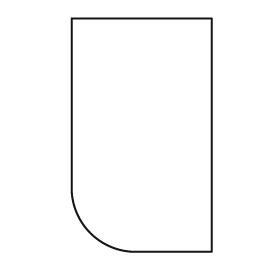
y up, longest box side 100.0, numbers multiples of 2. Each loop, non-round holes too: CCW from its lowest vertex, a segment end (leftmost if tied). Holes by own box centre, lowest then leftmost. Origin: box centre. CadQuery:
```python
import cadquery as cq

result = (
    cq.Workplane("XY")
    .moveTo(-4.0, -50.0)
    .lineTo(30.0, -50.0)
    .lineTo(30.0, 50.0)
    .lineTo(-30.0, 50.0)
    .lineTo(-30.0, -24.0)
    .threePointArc((-22.0, -42.0), (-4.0, -50.0))
    .close()
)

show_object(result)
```